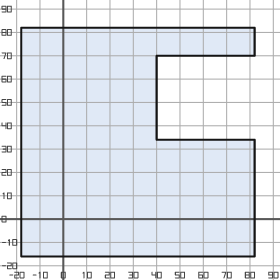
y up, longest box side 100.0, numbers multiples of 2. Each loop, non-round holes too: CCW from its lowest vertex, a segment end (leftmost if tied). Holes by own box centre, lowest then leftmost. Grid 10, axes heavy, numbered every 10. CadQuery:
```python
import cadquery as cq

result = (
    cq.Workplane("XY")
    .moveTo(-18.0, -16.0)
    .lineTo(82.0, -16.0)
    .lineTo(82.0, 34.0)
    .lineTo(40.0, 34.0)
    .lineTo(40.0, 70.0)
    .lineTo(82.0, 70.0)
    .lineTo(82.0, 82.0)
    .lineTo(-18.0, 82.0)
    .close()
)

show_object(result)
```